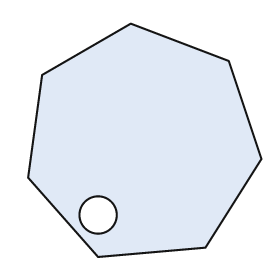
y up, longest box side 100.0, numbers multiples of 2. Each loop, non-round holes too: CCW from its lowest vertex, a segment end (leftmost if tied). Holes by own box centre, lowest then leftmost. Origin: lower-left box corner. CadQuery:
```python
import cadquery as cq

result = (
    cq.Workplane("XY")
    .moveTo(30.0, 0.0)
    .lineTo(76.0, 4.0)
    .lineTo(100.0, 42.0)
    .lineTo(86.0, 84.0)
    .lineTo(44.0, 100.0)
    .lineTo(6.0, 78.0)
    .lineTo(0.0, 34.0)
    .close()
    .moveTo(30.0, 18.0)
    .circle(8.0)
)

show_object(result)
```